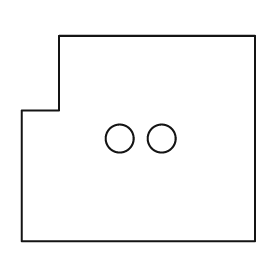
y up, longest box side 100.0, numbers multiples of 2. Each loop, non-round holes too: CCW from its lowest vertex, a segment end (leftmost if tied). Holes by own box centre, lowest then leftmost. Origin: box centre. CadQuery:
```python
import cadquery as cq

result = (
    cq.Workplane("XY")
    .moveTo(-50.0, -44.0)
    .lineTo(50.0, -44.0)
    .lineTo(50.0, 44.0)
    .lineTo(-34.0, 44.0)
    .lineTo(-34.0, 12.0)
    .lineTo(-50.0, 12.0)
    .close()
    .moveTo(-8.0, 0.0)
    .circle(6.0)
    .moveTo(10.0, 0.0)
    .circle(6.0)
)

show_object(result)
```